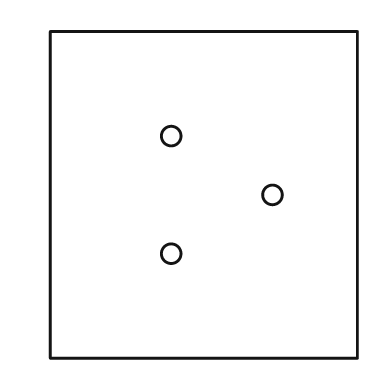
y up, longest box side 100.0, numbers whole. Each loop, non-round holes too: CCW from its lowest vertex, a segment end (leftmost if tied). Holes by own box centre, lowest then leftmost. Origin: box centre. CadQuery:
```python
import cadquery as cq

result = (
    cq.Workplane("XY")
    .moveTo(-47.0, -50.0)
    .lineTo(47.0, -50.0)
    .lineTo(47.0, 50.0)
    .lineTo(-47.0, 50.0)
    .close()
    .moveTo(-10.0, -18.0)
    .circle(3.0)
    .moveTo(21.0, 0.0)
    .circle(3.0)
    .moveTo(-10.0, 18.0)
    .circle(3.0)
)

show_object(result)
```